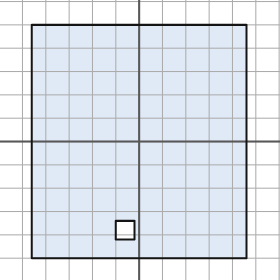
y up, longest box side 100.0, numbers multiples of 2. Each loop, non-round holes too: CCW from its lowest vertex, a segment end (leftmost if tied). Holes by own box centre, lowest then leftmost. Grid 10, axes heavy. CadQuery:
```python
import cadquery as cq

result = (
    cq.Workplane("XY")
    .moveTo(-46.0, -50.0)
    .lineTo(46.0, -50.0)
    .lineTo(46.0, 50.0)
    .lineTo(-46.0, 50.0)
    .close()
    .moveTo(-10.0, -42.0)
    .lineTo(-2.0, -42.0)
    .lineTo(-2.0, -34.0)
    .lineTo(-10.0, -34.0)
    .close()
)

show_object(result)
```